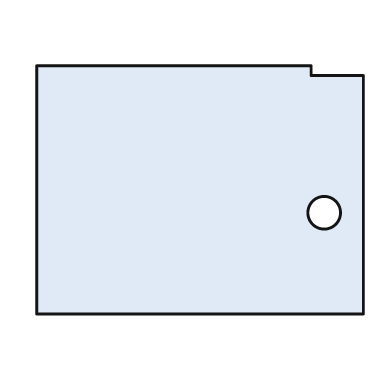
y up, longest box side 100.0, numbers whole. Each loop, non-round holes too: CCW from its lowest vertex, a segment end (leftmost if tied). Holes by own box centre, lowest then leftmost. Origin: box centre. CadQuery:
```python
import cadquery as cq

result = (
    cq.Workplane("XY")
    .moveTo(-50.0, -38.0)
    .lineTo(50.0, -38.0)
    .lineTo(50.0, 35.0)
    .lineTo(34.0, 35.0)
    .lineTo(34.0, 38.0)
    .lineTo(-50.0, 38.0)
    .close()
    .moveTo(38.0, -7.0)
    .circle(5.0)
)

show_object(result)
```